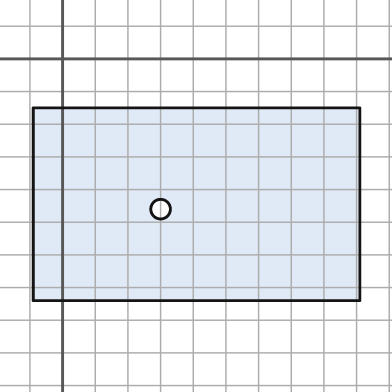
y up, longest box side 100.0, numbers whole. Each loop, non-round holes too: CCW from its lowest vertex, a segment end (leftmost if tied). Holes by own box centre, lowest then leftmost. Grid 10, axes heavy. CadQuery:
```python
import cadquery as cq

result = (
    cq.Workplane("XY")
    .moveTo(-9.0, -74.0)
    .lineTo(91.0, -74.0)
    .lineTo(91.0, -15.0)
    .lineTo(-9.0, -15.0)
    .close()
    .moveTo(30.0, -46.0)
    .circle(3.0)
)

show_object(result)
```